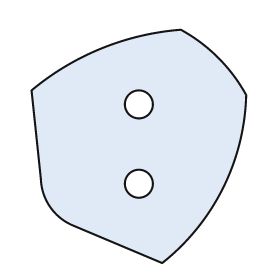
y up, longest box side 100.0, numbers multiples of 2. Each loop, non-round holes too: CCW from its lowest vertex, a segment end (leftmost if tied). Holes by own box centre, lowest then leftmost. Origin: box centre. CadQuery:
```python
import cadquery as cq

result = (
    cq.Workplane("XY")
    .moveTo(10.0, -50.0)
    .threePointArc((36.0, -18.0), (46.0, 22.0))
    .threePointArc((34.0, 38.0), (18.0, 50.0))
    .threePointArc((-16.0, 42.0), (-46.0, 24.0))
    .lineTo(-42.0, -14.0)
    .threePointArc((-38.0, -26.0), (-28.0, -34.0))
    .close()
    .moveTo(0.0, -16.0)
    .circle(6.0)
    .moveTo(0.0, 18.0)
    .circle(6.0)
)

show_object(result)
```